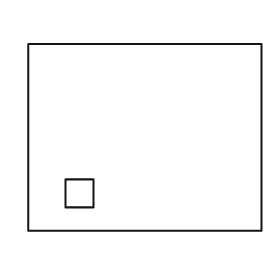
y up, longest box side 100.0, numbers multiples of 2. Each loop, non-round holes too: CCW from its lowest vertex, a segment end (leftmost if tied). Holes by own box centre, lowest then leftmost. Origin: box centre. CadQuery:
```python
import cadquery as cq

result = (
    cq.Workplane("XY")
    .moveTo(-50.0, -40.0)
    .lineTo(50.0, -40.0)
    .lineTo(50.0, 40.0)
    .lineTo(-50.0, 40.0)
    .close()
    .moveTo(-34.0, -30.0)
    .lineTo(-22.0, -30.0)
    .lineTo(-22.0, -18.0)
    .lineTo(-34.0, -18.0)
    .close()
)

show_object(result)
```